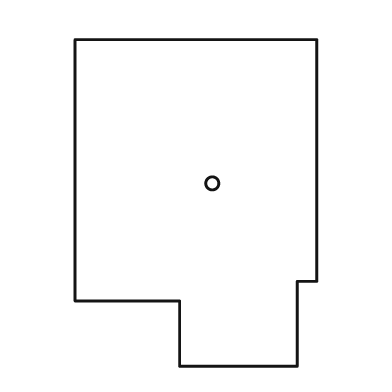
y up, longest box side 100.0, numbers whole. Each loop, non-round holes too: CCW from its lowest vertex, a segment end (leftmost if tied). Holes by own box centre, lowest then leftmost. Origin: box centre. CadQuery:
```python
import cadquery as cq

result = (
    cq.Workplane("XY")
    .moveTo(-5.0, -50.0)
    .lineTo(31.0, -50.0)
    .lineTo(31.0, -24.0)
    .lineTo(37.0, -24.0)
    .lineTo(37.0, 50.0)
    .lineTo(-37.0, 50.0)
    .lineTo(-37.0, -30.0)
    .lineTo(-5.0, -30.0)
    .close()
    .moveTo(5.0, 6.0)
    .circle(2.0)
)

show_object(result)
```